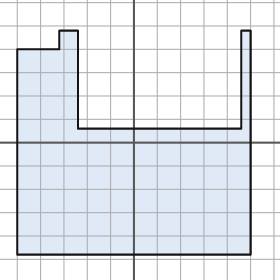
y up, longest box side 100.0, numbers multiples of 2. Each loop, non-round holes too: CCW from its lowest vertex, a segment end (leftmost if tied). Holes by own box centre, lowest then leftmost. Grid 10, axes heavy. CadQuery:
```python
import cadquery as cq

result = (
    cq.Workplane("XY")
    .moveTo(-50.0, -48.0)
    .lineTo(50.0, -48.0)
    .lineTo(50.0, 48.0)
    .lineTo(46.0, 48.0)
    .lineTo(46.0, 6.0)
    .lineTo(-24.0, 6.0)
    .lineTo(-24.0, 48.0)
    .lineTo(-32.0, 48.0)
    .lineTo(-32.0, 40.0)
    .lineTo(-50.0, 40.0)
    .close()
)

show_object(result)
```